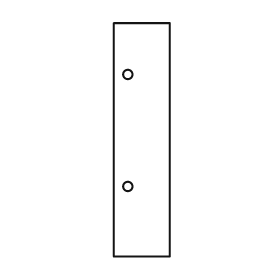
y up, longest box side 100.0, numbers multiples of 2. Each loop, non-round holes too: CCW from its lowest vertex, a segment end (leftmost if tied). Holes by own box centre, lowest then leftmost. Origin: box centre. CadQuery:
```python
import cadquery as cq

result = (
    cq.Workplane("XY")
    .moveTo(-12.0, -50.0)
    .lineTo(12.0, -50.0)
    .lineTo(12.0, 50.0)
    .lineTo(-12.0, 50.0)
    .close()
    .moveTo(-6.0, -20.0)
    .circle(2.0)
    .moveTo(-6.0, 28.0)
    .circle(2.0)
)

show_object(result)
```